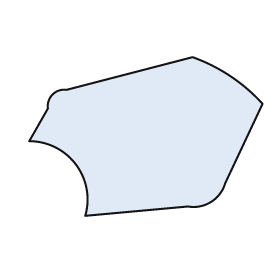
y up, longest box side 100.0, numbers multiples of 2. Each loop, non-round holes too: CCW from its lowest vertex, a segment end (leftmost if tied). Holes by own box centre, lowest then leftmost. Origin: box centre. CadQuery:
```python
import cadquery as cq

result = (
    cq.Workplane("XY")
    .moveTo(-26.0, -34.0)
    .lineTo(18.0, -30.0)
    .threePointArc((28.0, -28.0), (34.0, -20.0))
    .lineTo(50.0, 14.0)
    .threePointArc((36.0, 26.0), (20.0, 34.0))
    .lineTo(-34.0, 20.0)
    .threePointArc((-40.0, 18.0), (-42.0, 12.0))
    .lineTo(-50.0, -2.0)
    .threePointArc((-30.0, -12.0), (-26.0, -34.0))
    .close()
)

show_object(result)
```